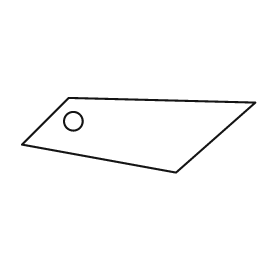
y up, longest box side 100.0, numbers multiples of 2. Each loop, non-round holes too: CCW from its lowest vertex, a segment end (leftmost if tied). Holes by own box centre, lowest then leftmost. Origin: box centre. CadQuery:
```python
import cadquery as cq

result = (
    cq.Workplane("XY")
    .moveTo(16.0, -16.0)
    .lineTo(50.0, 14.0)
    .lineTo(-30.0, 16.0)
    .lineTo(-50.0, -4.0)
    .close()
    .moveTo(-28.0, 6.0)
    .circle(4.0)
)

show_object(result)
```